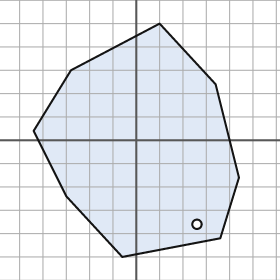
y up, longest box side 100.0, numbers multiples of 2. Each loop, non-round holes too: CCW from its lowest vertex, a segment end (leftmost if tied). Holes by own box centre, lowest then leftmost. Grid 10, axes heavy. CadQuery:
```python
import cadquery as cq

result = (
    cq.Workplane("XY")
    .moveTo(-6.0, -50.0)
    .lineTo(36.0, -42.0)
    .lineTo(44.0, -16.0)
    .lineTo(34.0, 24.0)
    .lineTo(10.0, 50.0)
    .lineTo(-28.0, 30.0)
    .lineTo(-44.0, 4.0)
    .lineTo(-30.0, -24.0)
    .close()
    .moveTo(26.0, -36.0)
    .circle(2.0)
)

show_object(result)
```